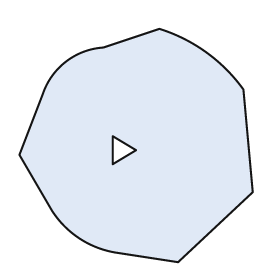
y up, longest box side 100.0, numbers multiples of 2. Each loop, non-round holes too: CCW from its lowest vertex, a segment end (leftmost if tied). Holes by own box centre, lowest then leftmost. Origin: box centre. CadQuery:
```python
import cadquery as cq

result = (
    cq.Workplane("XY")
    .moveTo(18.0, -50.0)
    .lineTo(50.0, -20.0)
    .lineTo(46.0, 24.0)
    .threePointArc((30.0, 40.0), (10.0, 50.0))
    .lineTo(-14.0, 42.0)
    .threePointArc((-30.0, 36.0), (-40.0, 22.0))
    .lineTo(-50.0, -4.0)
    .lineTo(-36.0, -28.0)
    .threePointArc((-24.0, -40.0), (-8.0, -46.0))
    .close()
    .moveTo(-10.0, -8.0)
    .lineTo(0.0, -2.0)
    .lineTo(-10.0, 4.0)
    .close()
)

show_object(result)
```